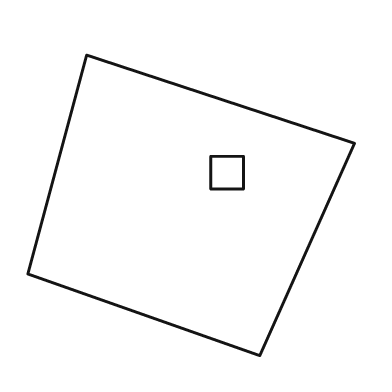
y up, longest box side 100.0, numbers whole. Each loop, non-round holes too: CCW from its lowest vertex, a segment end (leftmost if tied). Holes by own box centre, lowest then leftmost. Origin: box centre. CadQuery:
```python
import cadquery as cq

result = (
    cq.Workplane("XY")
    .moveTo(21.0, -46.0)
    .lineTo(50.0, 19.0)
    .lineTo(-32.0, 46.0)
    .lineTo(-50.0, -21.0)
    .close()
    .moveTo(6.0, 5.0)
    .lineTo(16.0, 5.0)
    .lineTo(16.0, 15.0)
    .lineTo(6.0, 15.0)
    .close()
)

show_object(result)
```